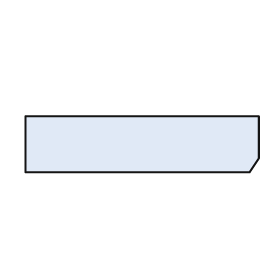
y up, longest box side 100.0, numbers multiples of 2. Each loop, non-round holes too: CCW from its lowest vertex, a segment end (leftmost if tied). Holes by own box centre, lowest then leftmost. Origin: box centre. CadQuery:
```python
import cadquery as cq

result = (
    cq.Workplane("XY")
    .moveTo(-50.0, -12.0)
    .lineTo(46.0, -12.0)
    .lineTo(50.0, -6.0)
    .lineTo(50.0, 12.0)
    .lineTo(-50.0, 12.0)
    .close()
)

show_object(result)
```